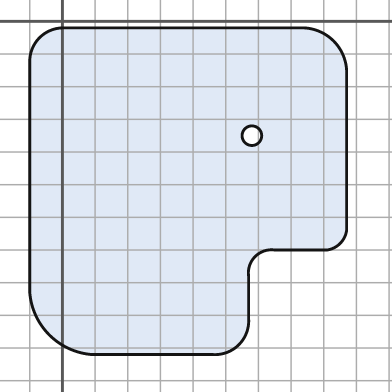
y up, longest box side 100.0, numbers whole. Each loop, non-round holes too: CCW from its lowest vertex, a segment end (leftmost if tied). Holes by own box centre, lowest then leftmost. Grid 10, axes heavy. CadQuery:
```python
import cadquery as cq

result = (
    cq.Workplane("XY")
    .moveTo(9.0, -102.0)
    .lineTo(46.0, -102.0)
    .threePointArc((54.0, -99.0), (57.0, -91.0))
    .lineTo(57.0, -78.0)
    .threePointArc((59.0, -72.0), (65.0, -70.0))
    .lineTo(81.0, -70.0)
    .threePointArc((85.0, -68.0), (87.0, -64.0))
    .lineTo(87.0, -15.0)
    .threePointArc((83.0, -6.0), (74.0, -2.0))
    .lineTo(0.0, -2.0)
    .threePointArc((-7.0, -5.0), (-10.0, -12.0))
    .lineTo(-10.0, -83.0)
    .threePointArc((-4.0, -96.0), (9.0, -102.0))
    .close()
    .moveTo(58.0, -35.0)
    .circle(3.0)
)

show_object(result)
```